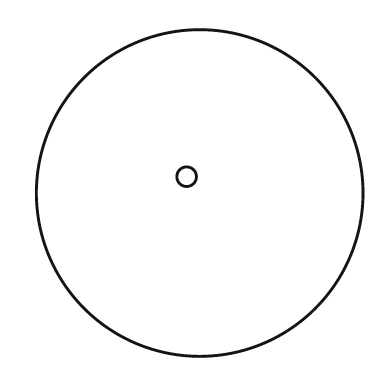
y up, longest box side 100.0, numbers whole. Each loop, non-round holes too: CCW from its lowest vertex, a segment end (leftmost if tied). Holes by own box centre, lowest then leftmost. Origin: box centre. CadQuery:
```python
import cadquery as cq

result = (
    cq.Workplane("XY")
    .moveTo(0.0, 0.0)
    .circle(50.0)
    .moveTo(-4.0, 5.0)
    .circle(3.0)
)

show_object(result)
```